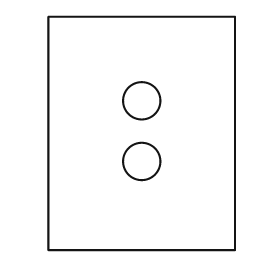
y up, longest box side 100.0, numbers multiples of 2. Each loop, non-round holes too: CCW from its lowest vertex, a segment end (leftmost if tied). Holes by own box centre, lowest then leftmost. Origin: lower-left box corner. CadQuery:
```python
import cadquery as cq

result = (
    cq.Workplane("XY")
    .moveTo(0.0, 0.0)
    .lineTo(80.0, 0.0)
    .lineTo(80.0, 100.0)
    .lineTo(0.0, 100.0)
    .close()
    .moveTo(40.0, 38.0)
    .circle(8.0)
    .moveTo(40.0, 64.0)
    .circle(8.0)
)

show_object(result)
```